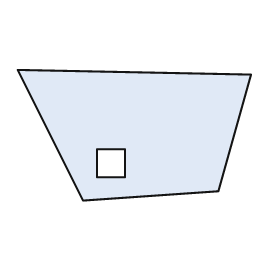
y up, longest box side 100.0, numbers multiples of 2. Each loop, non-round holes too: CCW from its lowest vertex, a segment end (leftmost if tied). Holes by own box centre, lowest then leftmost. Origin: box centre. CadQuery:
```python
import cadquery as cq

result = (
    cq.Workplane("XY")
    .moveTo(-22.0, -28.0)
    .lineTo(36.0, -24.0)
    .lineTo(50.0, 26.0)
    .lineTo(-50.0, 28.0)
    .close()
    .moveTo(-16.0, -18.0)
    .lineTo(-4.0, -18.0)
    .lineTo(-4.0, -6.0)
    .lineTo(-16.0, -6.0)
    .close()
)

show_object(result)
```